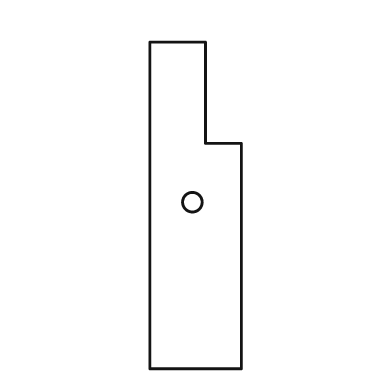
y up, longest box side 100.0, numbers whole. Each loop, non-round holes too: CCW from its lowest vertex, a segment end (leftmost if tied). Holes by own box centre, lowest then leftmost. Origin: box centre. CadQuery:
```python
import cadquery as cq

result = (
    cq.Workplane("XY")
    .moveTo(-14.0, -50.0)
    .lineTo(14.0, -50.0)
    .lineTo(14.0, 19.0)
    .lineTo(3.0, 19.0)
    .lineTo(3.0, 50.0)
    .lineTo(-14.0, 50.0)
    .close()
    .moveTo(-1.0, 1.0)
    .circle(3.0)
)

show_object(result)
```